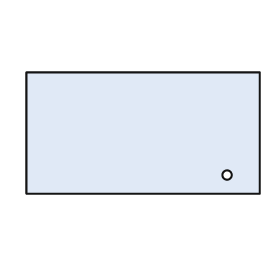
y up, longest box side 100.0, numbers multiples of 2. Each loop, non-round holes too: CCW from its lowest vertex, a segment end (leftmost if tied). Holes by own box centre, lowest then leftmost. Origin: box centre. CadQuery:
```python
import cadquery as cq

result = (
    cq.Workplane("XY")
    .moveTo(-50.0, -26.0)
    .lineTo(50.0, -26.0)
    .lineTo(50.0, 26.0)
    .lineTo(-50.0, 26.0)
    .close()
    .moveTo(36.0, -18.0)
    .circle(2.0)
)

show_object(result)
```